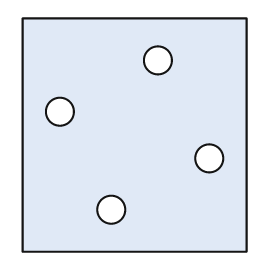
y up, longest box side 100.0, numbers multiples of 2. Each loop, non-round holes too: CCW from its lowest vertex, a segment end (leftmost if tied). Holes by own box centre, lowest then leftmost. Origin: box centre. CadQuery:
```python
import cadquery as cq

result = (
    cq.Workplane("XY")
    .moveTo(-48.0, -50.0)
    .lineTo(48.0, -50.0)
    .lineTo(48.0, 50.0)
    .lineTo(-48.0, 50.0)
    .close()
    .moveTo(-10.0, -32.0)
    .circle(6.0)
    .moveTo(32.0, -10.0)
    .circle(6.0)
    .moveTo(-32.0, 10.0)
    .circle(6.0)
    .moveTo(10.0, 32.0)
    .circle(6.0)
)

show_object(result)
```